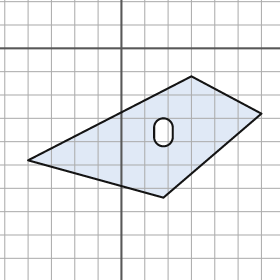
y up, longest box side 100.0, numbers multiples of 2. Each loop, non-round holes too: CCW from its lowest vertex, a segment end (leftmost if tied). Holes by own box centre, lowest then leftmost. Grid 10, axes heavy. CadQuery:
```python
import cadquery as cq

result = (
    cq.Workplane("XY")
    .moveTo(18.0, -64.0)
    .lineTo(60.0, -28.0)
    .lineTo(30.0, -12.0)
    .lineTo(-40.0, -48.0)
    .close()
    .moveTo(14.0, -38.0)
    .threePointArc((18.0, -42.0), (22.0, -38.0))
    .lineTo(22.0, -34.0)
    .threePointArc((18.0, -30.0), (14.0, -34.0))
    .close()
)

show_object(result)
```